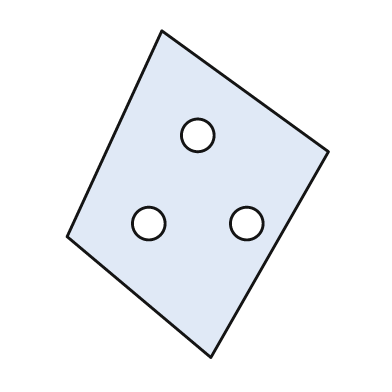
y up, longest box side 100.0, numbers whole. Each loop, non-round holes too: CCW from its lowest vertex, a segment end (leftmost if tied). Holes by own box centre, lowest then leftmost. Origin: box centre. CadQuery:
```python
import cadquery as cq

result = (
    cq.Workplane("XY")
    .moveTo(4.0, -50.0)
    .lineTo(40.0, 13.0)
    .lineTo(-11.0, 50.0)
    .lineTo(-40.0, -13.0)
    .close()
    .moveTo(-15.0, -9.0)
    .circle(5.0)
    .moveTo(15.0, -9.0)
    .circle(5.0)
    .moveTo(0.0, 18.0)
    .circle(5.0)
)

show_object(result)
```